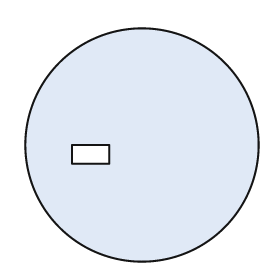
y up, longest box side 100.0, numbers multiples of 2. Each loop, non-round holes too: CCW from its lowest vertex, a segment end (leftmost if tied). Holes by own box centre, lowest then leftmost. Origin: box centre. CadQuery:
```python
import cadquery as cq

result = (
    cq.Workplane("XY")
    .moveTo(0.0, 0.0)
    .circle(50.0)
    .moveTo(-30.0, -8.0)
    .lineTo(-14.0, -8.0)
    .lineTo(-14.0, 0.0)
    .lineTo(-30.0, 0.0)
    .close()
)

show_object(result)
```